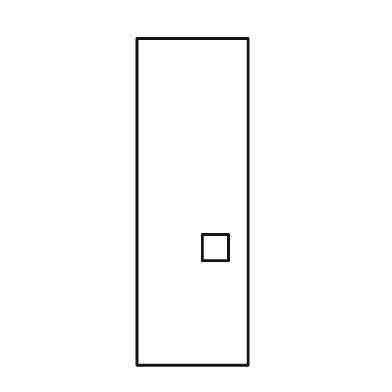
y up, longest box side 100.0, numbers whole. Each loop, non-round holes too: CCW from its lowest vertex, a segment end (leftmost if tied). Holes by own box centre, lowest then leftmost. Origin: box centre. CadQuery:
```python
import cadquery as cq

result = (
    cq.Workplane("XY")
    .moveTo(-17.0, -50.0)
    .lineTo(17.0, -50.0)
    .lineTo(17.0, 50.0)
    .lineTo(-17.0, 50.0)
    .close()
    .moveTo(3.0, -18.0)
    .lineTo(11.0, -18.0)
    .lineTo(11.0, -10.0)
    .lineTo(3.0, -10.0)
    .close()
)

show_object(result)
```